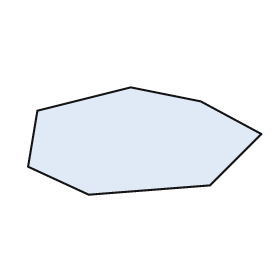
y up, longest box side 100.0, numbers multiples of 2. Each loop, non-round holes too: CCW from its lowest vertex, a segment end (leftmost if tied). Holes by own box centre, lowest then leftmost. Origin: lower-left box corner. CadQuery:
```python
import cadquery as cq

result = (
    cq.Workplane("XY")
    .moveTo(26.0, 0.0)
    .lineTo(78.0, 4.0)
    .lineTo(100.0, 26.0)
    .lineTo(74.0, 40.0)
    .lineTo(44.0, 46.0)
    .lineTo(4.0, 36.0)
    .lineTo(0.0, 12.0)
    .close()
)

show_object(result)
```